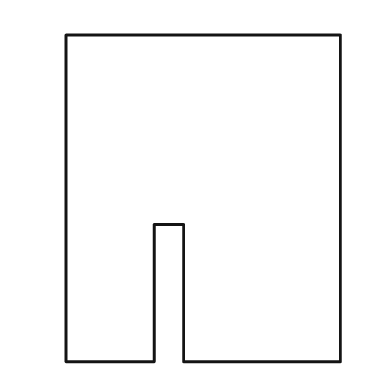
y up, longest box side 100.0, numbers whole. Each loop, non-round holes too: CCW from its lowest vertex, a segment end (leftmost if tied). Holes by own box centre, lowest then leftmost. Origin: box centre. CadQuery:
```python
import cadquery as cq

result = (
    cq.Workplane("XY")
    .moveTo(-42.0, -50.0)
    .lineTo(-15.0, -50.0)
    .lineTo(-15.0, -8.0)
    .lineTo(-6.0, -8.0)
    .lineTo(-6.0, -50.0)
    .lineTo(42.0, -50.0)
    .lineTo(42.0, 50.0)
    .lineTo(-42.0, 50.0)
    .close()
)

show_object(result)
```